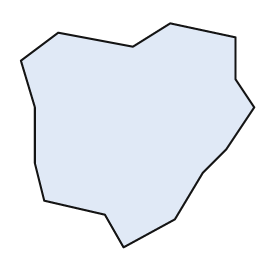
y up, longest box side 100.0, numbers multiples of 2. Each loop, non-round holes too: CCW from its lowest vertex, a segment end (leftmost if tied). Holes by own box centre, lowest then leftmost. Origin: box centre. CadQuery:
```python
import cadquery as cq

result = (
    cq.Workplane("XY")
    .moveTo(-6.0, -48.0)
    .lineTo(16.0, -36.0)
    .lineTo(28.0, -16.0)
    .lineTo(38.0, -6.0)
    .lineTo(50.0, 12.0)
    .lineTo(42.0, 24.0)
    .lineTo(42.0, 42.0)
    .lineTo(14.0, 48.0)
    .lineTo(-2.0, 38.0)
    .lineTo(-34.0, 44.0)
    .lineTo(-50.0, 32.0)
    .lineTo(-44.0, 12.0)
    .lineTo(-44.0, -12.0)
    .lineTo(-40.0, -28.0)
    .lineTo(-14.0, -34.0)
    .close()
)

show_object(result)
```